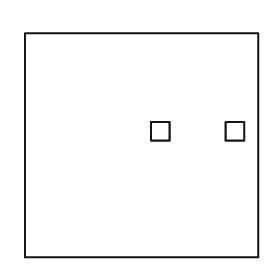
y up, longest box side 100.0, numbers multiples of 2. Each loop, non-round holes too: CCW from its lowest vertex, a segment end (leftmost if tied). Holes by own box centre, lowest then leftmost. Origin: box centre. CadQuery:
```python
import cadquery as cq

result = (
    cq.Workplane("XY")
    .moveTo(-50.0, -48.0)
    .lineTo(50.0, -48.0)
    .lineTo(50.0, 48.0)
    .lineTo(-50.0, 48.0)
    .close()
    .moveTo(4.0, 2.0)
    .lineTo(12.0, 2.0)
    .lineTo(12.0, 10.0)
    .lineTo(4.0, 10.0)
    .close()
    .moveTo(36.0, 2.0)
    .lineTo(44.0, 2.0)
    .lineTo(44.0, 10.0)
    .lineTo(36.0, 10.0)
    .close()
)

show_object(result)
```